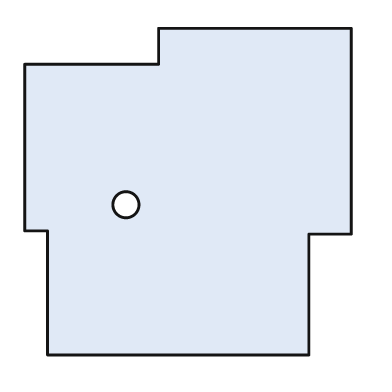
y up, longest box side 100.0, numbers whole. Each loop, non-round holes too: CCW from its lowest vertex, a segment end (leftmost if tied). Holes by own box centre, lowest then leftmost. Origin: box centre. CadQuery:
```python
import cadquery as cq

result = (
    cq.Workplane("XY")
    .moveTo(-43.0, -50.0)
    .lineTo(37.0, -50.0)
    .lineTo(37.0, -13.0)
    .lineTo(50.0, -13.0)
    .lineTo(50.0, 50.0)
    .lineTo(-9.0, 50.0)
    .lineTo(-9.0, 39.0)
    .lineTo(-50.0, 39.0)
    .lineTo(-50.0, -12.0)
    .lineTo(-43.0, -12.0)
    .close()
    .moveTo(-19.0, -4.0)
    .circle(4.0)
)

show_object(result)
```